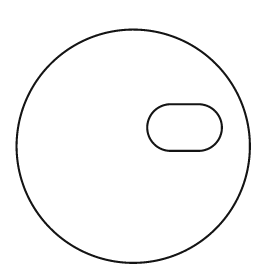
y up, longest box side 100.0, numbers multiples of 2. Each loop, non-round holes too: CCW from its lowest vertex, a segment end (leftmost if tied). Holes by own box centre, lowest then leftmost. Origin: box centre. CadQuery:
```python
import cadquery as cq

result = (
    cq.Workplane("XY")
    .moveTo(0.0, 0.0)
    .circle(50.0)
    .moveTo(16.0, -2.0)
    .lineTo(28.0, -2.0)
    .threePointArc((38.0, 8.0), (28.0, 18.0))
    .lineTo(16.0, 18.0)
    .threePointArc((6.0, 8.0), (16.0, -2.0))
    .close()
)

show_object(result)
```